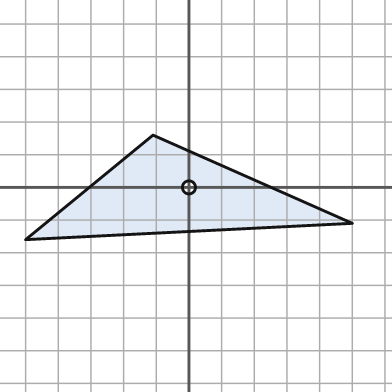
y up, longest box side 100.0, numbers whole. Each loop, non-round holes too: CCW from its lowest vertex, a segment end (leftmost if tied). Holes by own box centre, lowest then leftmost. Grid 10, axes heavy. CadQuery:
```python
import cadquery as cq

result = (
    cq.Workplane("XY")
    .moveTo(-50.0, -16.0)
    .lineTo(50.0, -11.0)
    .lineTo(-11.0, 16.0)
    .close()
    .moveTo(0.0, 0.0)
    .circle(2.0)
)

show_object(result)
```